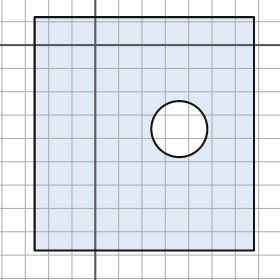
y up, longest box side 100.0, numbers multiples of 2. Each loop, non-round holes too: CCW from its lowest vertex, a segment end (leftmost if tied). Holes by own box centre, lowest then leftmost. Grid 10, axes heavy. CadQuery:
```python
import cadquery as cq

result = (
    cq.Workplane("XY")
    .moveTo(-26.0, -88.0)
    .lineTo(68.0, -88.0)
    .lineTo(68.0, 12.0)
    .lineTo(-26.0, 12.0)
    .close()
    .moveTo(36.0, -36.0)
    .circle(12.0)
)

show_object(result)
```